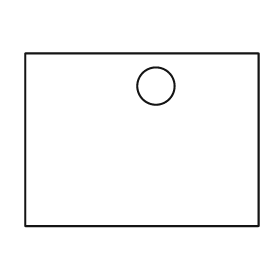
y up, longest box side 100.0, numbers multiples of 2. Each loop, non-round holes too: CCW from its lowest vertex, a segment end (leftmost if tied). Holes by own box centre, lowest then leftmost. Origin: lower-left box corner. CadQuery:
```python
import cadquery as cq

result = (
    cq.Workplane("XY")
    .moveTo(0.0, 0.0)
    .lineTo(100.0, 0.0)
    .lineTo(100.0, 74.0)
    .lineTo(0.0, 74.0)
    .close()
    .moveTo(56.0, 60.0)
    .circle(8.0)
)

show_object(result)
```